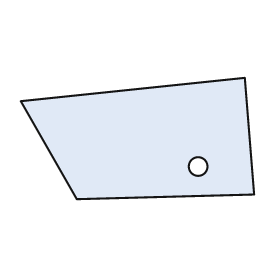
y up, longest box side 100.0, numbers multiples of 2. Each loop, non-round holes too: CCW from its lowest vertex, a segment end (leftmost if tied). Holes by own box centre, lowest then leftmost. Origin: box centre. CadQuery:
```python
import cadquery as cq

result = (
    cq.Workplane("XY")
    .moveTo(-26.0, -26.0)
    .lineTo(50.0, -24.0)
    .lineTo(46.0, 26.0)
    .lineTo(-50.0, 16.0)
    .close()
    .moveTo(26.0, -12.0)
    .circle(4.0)
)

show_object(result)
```